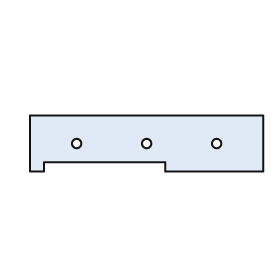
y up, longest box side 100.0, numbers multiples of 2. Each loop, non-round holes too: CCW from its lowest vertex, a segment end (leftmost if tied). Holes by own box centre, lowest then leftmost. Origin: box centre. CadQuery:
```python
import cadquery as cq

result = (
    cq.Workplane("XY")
    .moveTo(-50.0, -12.0)
    .lineTo(-44.0, -12.0)
    .lineTo(-44.0, -8.0)
    .lineTo(8.0, -8.0)
    .lineTo(8.0, -12.0)
    .lineTo(50.0, -12.0)
    .lineTo(50.0, 12.0)
    .lineTo(-50.0, 12.0)
    .close()
    .moveTo(-30.0, 0.0)
    .circle(2.0)
    .moveTo(0.0, 0.0)
    .circle(2.0)
    .moveTo(30.0, 0.0)
    .circle(2.0)
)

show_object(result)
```